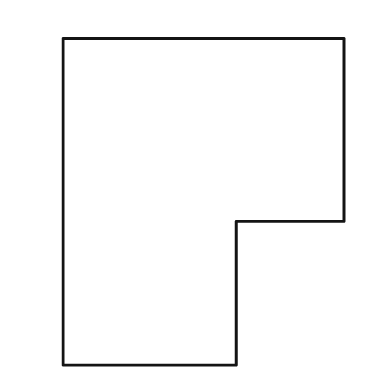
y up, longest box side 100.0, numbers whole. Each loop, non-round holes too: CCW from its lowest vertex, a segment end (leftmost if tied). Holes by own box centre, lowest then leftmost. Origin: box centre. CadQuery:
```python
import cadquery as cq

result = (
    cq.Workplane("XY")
    .moveTo(-43.0, -50.0)
    .lineTo(10.0, -50.0)
    .lineTo(10.0, -6.0)
    .lineTo(43.0, -6.0)
    .lineTo(43.0, 50.0)
    .lineTo(-43.0, 50.0)
    .close()
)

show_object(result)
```